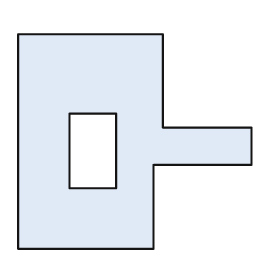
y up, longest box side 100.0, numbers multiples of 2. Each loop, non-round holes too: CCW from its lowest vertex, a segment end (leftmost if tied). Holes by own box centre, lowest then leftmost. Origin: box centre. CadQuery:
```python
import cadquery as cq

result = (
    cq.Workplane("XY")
    .moveTo(-50.0, -46.0)
    .lineTo(8.0, -46.0)
    .lineTo(8.0, -10.0)
    .lineTo(50.0, -10.0)
    .lineTo(50.0, 6.0)
    .lineTo(12.0, 6.0)
    .lineTo(12.0, 46.0)
    .lineTo(-50.0, 46.0)
    .close()
    .moveTo(-28.0, -20.0)
    .lineTo(-8.0, -20.0)
    .lineTo(-8.0, 12.0)
    .lineTo(-28.0, 12.0)
    .close()
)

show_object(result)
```